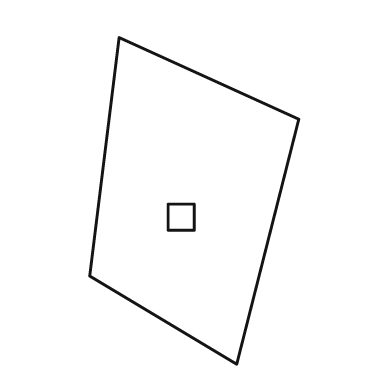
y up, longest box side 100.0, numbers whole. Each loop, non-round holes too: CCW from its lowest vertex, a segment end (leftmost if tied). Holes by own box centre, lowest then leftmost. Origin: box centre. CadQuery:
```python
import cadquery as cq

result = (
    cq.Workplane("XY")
    .moveTo(13.0, -50.0)
    .lineTo(32.0, 25.0)
    .lineTo(-23.0, 50.0)
    .lineTo(-32.0, -23.0)
    .close()
    .moveTo(-8.0, -9.0)
    .lineTo(0.0, -9.0)
    .lineTo(0.0, -1.0)
    .lineTo(-8.0, -1.0)
    .close()
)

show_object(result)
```